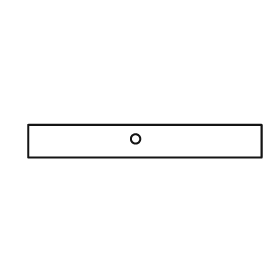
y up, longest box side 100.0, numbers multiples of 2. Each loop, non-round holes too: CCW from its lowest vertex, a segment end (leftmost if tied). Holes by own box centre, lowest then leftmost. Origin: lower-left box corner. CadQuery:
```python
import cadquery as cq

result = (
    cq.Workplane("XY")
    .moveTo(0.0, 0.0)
    .lineTo(100.0, 0.0)
    .lineTo(100.0, 14.0)
    .lineTo(0.0, 14.0)
    .close()
    .moveTo(46.0, 8.0)
    .circle(2.0)
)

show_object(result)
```